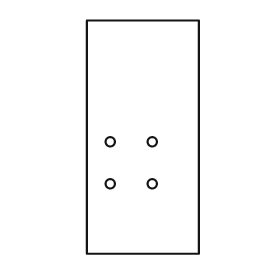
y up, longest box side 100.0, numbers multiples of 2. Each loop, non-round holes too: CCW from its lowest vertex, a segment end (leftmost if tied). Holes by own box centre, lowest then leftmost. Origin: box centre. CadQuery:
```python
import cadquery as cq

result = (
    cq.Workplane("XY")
    .moveTo(-24.0, -50.0)
    .lineTo(24.0, -50.0)
    .lineTo(24.0, 50.0)
    .lineTo(-24.0, 50.0)
    .close()
    .moveTo(-14.0, -20.0)
    .circle(2.0)
    .moveTo(4.0, -20.0)
    .circle(2.0)
    .moveTo(-14.0, -2.0)
    .circle(2.0)
    .moveTo(4.0, -2.0)
    .circle(2.0)
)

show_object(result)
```